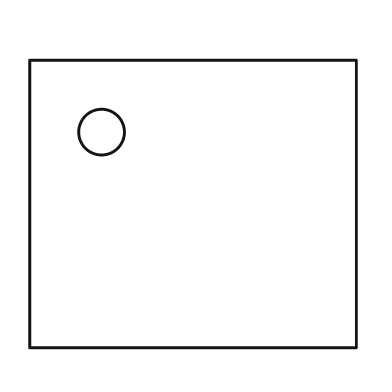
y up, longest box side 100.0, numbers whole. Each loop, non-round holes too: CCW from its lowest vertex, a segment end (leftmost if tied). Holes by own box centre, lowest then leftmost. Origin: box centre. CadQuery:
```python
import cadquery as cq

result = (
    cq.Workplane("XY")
    .moveTo(-50.0, -44.0)
    .lineTo(50.0, -44.0)
    .lineTo(50.0, 44.0)
    .lineTo(-50.0, 44.0)
    .close()
    .moveTo(-28.0, 22.0)
    .circle(7.0)
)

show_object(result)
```